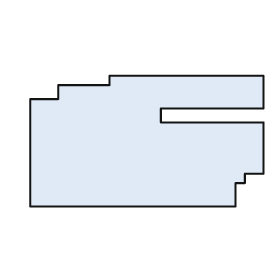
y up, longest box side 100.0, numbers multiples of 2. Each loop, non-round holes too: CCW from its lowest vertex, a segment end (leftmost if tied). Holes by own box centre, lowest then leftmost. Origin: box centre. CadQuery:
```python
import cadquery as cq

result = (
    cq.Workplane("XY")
    .moveTo(-50.0, -28.0)
    .lineTo(38.0, -28.0)
    .lineTo(38.0, -18.0)
    .lineTo(42.0, -18.0)
    .lineTo(42.0, -14.0)
    .lineTo(50.0, -14.0)
    .lineTo(50.0, 8.0)
    .lineTo(6.0, 8.0)
    .lineTo(6.0, 14.0)
    .lineTo(50.0, 14.0)
    .lineTo(50.0, 28.0)
    .lineTo(-16.0, 28.0)
    .lineTo(-16.0, 24.0)
    .lineTo(-38.0, 24.0)
    .lineTo(-38.0, 18.0)
    .lineTo(-50.0, 18.0)
    .close()
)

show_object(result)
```